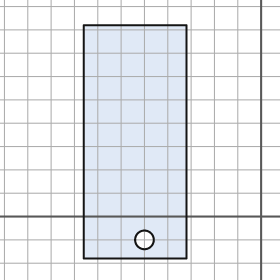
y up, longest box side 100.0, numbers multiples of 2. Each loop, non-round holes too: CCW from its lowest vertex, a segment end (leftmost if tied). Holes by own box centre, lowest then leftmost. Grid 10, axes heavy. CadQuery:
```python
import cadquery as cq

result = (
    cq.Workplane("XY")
    .moveTo(-76.0, -18.0)
    .lineTo(-32.0, -18.0)
    .lineTo(-32.0, 82.0)
    .lineTo(-76.0, 82.0)
    .close()
    .moveTo(-50.0, -10.0)
    .circle(4.0)
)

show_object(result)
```